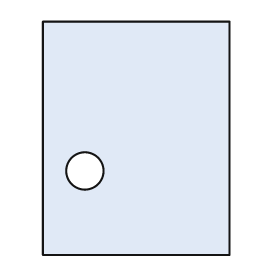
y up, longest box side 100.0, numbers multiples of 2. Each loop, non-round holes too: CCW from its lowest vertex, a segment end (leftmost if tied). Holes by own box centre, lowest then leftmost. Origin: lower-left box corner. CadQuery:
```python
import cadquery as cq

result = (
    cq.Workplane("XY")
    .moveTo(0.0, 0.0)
    .lineTo(80.0, 0.0)
    .lineTo(80.0, 100.0)
    .lineTo(0.0, 100.0)
    .close()
    .moveTo(18.0, 36.0)
    .circle(8.0)
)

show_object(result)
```